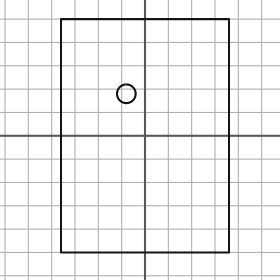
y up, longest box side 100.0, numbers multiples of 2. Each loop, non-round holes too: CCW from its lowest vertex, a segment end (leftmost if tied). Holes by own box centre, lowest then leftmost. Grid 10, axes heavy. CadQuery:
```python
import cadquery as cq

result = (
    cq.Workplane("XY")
    .moveTo(-36.0, -50.0)
    .lineTo(36.0, -50.0)
    .lineTo(36.0, 50.0)
    .lineTo(-36.0, 50.0)
    .close()
    .moveTo(-8.0, 18.0)
    .circle(4.0)
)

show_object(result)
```